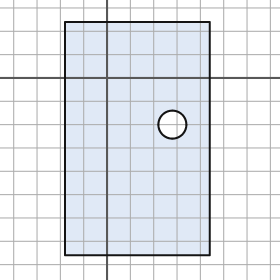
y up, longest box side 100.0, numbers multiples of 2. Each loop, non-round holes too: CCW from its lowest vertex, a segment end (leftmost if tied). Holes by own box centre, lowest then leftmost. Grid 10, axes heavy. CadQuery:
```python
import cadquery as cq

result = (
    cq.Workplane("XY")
    .moveTo(-18.0, -76.0)
    .lineTo(44.0, -76.0)
    .lineTo(44.0, 24.0)
    .lineTo(-18.0, 24.0)
    .close()
    .moveTo(28.0, -20.0)
    .circle(6.0)
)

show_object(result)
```